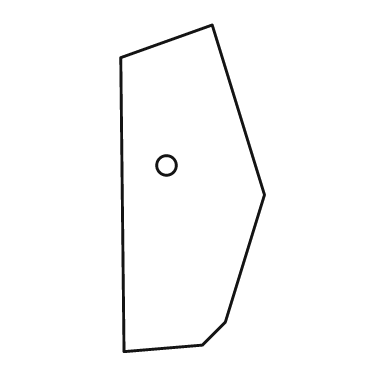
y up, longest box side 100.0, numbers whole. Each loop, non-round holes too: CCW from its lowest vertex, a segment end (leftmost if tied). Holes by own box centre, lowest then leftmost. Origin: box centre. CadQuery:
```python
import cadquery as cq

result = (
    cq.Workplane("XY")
    .moveTo(-21.0, -50.0)
    .lineTo(3.0, -48.0)
    .lineTo(10.0, -41.0)
    .lineTo(22.0, -2.0)
    .lineTo(6.0, 50.0)
    .lineTo(-22.0, 40.0)
    .close()
    .moveTo(-8.0, 7.0)
    .circle(3.0)
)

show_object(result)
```